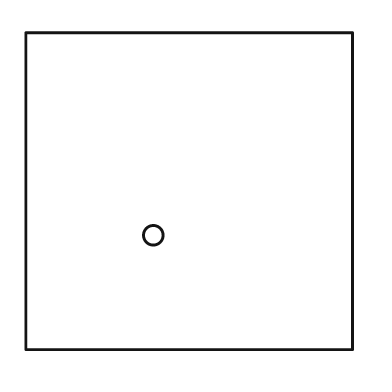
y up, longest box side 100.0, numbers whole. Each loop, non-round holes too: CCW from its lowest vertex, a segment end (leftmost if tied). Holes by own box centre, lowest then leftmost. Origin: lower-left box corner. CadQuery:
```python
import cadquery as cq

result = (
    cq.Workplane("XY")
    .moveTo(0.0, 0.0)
    .lineTo(100.0, 0.0)
    .lineTo(100.0, 97.0)
    .lineTo(0.0, 97.0)
    .close()
    .moveTo(39.0, 35.0)
    .circle(3.0)
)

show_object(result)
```